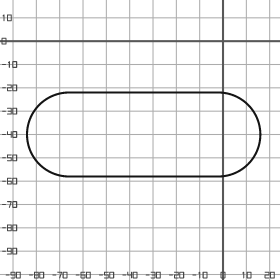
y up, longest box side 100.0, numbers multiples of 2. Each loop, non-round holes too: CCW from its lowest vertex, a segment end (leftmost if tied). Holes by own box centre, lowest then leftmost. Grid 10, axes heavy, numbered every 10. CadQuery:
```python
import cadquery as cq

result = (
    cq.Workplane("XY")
    .moveTo(-66.0, -58.0)
    .lineTo(-2.0, -58.0)
    .threePointArc((16.0, -40.0), (-2.0, -22.0))
    .lineTo(-66.0, -22.0)
    .threePointArc((-84.0, -40.0), (-66.0, -58.0))
    .close()
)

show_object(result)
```